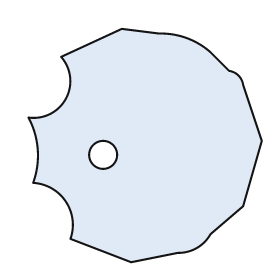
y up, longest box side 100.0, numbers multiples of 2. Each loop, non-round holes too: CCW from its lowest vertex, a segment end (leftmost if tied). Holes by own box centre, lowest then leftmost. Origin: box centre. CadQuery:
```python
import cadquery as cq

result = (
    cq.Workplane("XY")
    .moveTo(-6.0, -50.0)
    .lineTo(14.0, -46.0)
    .threePointArc((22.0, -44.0), (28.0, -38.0))
    .lineTo(42.0, -26.0)
    .lineTo(50.0, 2.0)
    .lineTo(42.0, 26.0)
    .threePointArc((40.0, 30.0), (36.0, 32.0))
    .lineTo(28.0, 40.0)
    .threePointArc((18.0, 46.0), (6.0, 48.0))
    .lineTo(-10.0, 50.0)
    .lineTo(-36.0, 38.0)
    .threePointArc((-34.0, 20.0), (-50.0, 12.0))
    .threePointArc((-46.0, -2.0), (-48.0, -16.0))
    .threePointArc((-34.0, -24.0), (-32.0, -40.0))
    .close()
    .moveTo(-18.0, -4.0)
    .circle(6.0)
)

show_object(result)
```